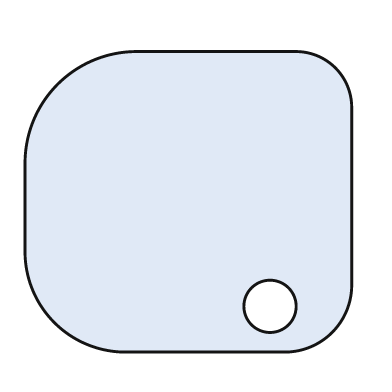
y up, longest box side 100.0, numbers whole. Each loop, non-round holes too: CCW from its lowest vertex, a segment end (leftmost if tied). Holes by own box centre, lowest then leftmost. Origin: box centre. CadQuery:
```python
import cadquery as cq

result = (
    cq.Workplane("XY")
    .moveTo(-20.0, -46.0)
    .lineTo(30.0, -46.0)
    .threePointArc((44.0, -40.0), (50.0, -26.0))
    .lineTo(50.0, 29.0)
    .threePointArc((45.0, 41.0), (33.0, 46.0))
    .lineTo(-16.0, 46.0)
    .threePointArc((-40.0, 36.0), (-50.0, 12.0))
    .lineTo(-50.0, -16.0)
    .threePointArc((-41.0, -37.0), (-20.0, -46.0))
    .close()
    .moveTo(25.0, -32.0)
    .circle(8.0)
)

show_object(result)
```